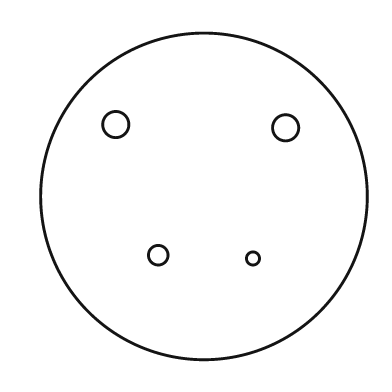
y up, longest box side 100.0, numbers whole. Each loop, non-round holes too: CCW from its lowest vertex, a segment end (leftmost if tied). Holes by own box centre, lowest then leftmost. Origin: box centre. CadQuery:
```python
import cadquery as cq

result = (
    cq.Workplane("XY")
    .moveTo(0.0, 0.0)
    .circle(50.0)
    .moveTo(15.0, -19.0)
    .circle(2.0)
    .moveTo(-14.0, -18.0)
    .circle(3.0)
    .moveTo(25.0, 21.0)
    .circle(4.0)
    .moveTo(-27.0, 22.0)
    .circle(4.0)
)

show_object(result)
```